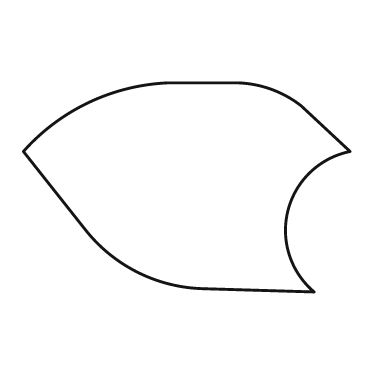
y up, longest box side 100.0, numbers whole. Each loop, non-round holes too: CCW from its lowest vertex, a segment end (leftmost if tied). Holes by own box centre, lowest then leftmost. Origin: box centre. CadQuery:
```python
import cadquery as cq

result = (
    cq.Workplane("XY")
    .moveTo(39.0, -32.0)
    .threePointArc((31.0, -7.0), (50.0, 11.0))
    .lineTo(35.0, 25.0)
    .threePointArc((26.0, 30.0), (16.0, 32.0))
    .lineTo(-6.0, 32.0)
    .threePointArc((-30.0, 26.0), (-50.0, 11.0))
    .lineTo(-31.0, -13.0)
    .threePointArc((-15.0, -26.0), (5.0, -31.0))
    .close()
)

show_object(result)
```